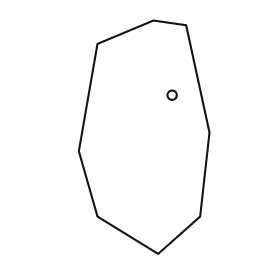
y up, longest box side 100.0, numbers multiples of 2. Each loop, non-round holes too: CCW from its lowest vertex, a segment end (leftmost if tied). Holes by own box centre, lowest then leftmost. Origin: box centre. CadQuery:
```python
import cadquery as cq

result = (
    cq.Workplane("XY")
    .moveTo(6.0, -50.0)
    .lineTo(24.0, -34.0)
    .lineTo(28.0, 2.0)
    .lineTo(18.0, 48.0)
    .lineTo(4.0, 50.0)
    .lineTo(-20.0, 40.0)
    .lineTo(-28.0, -6.0)
    .lineTo(-20.0, -34.0)
    .close()
    .moveTo(12.0, 18.0)
    .circle(2.0)
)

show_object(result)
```